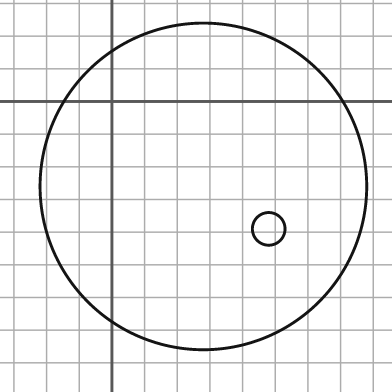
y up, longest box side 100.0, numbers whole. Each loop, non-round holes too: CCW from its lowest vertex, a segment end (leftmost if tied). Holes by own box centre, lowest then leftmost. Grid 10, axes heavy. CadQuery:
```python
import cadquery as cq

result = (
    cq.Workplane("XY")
    .moveTo(28.0, -26.0)
    .circle(50.0)
    .moveTo(48.0, -39.0)
    .circle(5.0)
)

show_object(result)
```